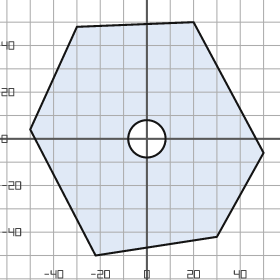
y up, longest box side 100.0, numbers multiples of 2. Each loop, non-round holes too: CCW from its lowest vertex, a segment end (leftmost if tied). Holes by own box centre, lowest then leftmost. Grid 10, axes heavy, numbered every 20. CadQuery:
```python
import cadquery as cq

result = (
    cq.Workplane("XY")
    .moveTo(-22.0, -50.0)
    .lineTo(30.0, -42.0)
    .lineTo(50.0, -6.0)
    .lineTo(20.0, 50.0)
    .lineTo(-30.0, 48.0)
    .lineTo(-50.0, 4.0)
    .close()
    .moveTo(0.0, 0.0)
    .circle(8.0)
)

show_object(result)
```